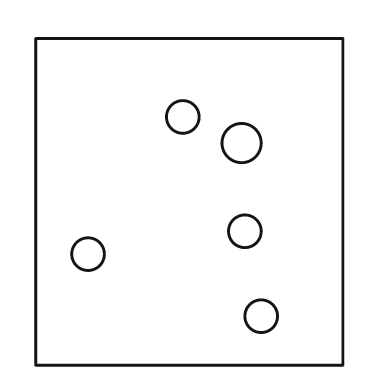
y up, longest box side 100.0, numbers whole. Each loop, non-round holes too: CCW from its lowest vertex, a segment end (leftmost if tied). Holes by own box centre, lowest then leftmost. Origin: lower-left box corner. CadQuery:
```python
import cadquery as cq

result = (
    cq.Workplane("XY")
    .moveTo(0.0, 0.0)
    .lineTo(94.0, 0.0)
    .lineTo(94.0, 100.0)
    .lineTo(0.0, 100.0)
    .close()
    .moveTo(69.0, 15.0)
    .circle(5.0)
    .moveTo(16.0, 34.0)
    .circle(5.0)
    .moveTo(64.0, 41.0)
    .circle(5.0)
    .moveTo(63.0, 68.0)
    .circle(6.0)
    .moveTo(45.0, 76.0)
    .circle(5.0)
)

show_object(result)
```